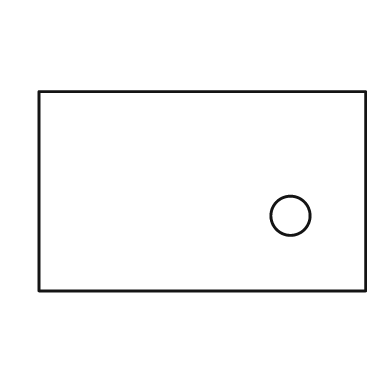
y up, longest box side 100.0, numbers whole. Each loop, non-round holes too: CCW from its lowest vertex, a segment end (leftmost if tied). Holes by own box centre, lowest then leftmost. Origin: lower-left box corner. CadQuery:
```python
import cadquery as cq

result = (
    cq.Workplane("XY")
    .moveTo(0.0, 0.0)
    .lineTo(100.0, 0.0)
    .lineTo(100.0, 61.0)
    .lineTo(0.0, 61.0)
    .close()
    .moveTo(77.0, 23.0)
    .circle(6.0)
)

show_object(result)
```